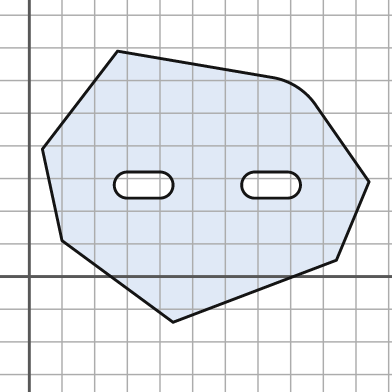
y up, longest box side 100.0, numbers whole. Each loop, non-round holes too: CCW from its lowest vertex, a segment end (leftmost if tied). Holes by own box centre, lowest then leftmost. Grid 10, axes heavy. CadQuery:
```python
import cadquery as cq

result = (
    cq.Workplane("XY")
    .moveTo(44.0, -14.0)
    .lineTo(94.0, 5.0)
    .lineTo(104.0, 29.0)
    .lineTo(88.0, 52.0)
    .threePointArc((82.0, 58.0), (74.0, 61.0))
    .lineTo(27.0, 69.0)
    .lineTo(4.0, 39.0)
    .lineTo(10.0, 11.0)
    .close()
    .moveTo(30.0, 24.0)
    .lineTo(40.0, 24.0)
    .threePointArc((44.0, 28.0), (40.0, 32.0))
    .lineTo(30.0, 32.0)
    .threePointArc((26.0, 28.0), (30.0, 24.0))
    .close()
    .moveTo(69.0, 24.0)
    .lineTo(79.0, 24.0)
    .threePointArc((83.0, 28.0), (79.0, 32.0))
    .lineTo(69.0, 32.0)
    .threePointArc((65.0, 28.0), (69.0, 24.0))
    .close()
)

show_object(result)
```